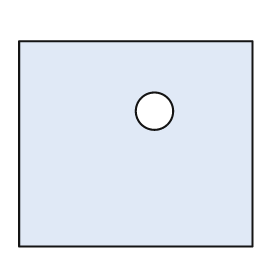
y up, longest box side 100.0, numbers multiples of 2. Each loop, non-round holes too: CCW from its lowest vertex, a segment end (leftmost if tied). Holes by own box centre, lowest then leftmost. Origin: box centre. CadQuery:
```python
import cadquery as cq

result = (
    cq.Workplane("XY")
    .moveTo(-50.0, -44.0)
    .lineTo(50.0, -44.0)
    .lineTo(50.0, 44.0)
    .lineTo(-50.0, 44.0)
    .close()
    .moveTo(8.0, 14.0)
    .circle(8.0)
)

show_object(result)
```